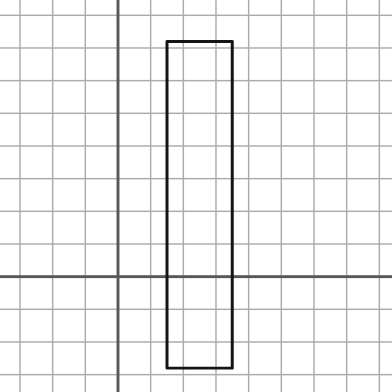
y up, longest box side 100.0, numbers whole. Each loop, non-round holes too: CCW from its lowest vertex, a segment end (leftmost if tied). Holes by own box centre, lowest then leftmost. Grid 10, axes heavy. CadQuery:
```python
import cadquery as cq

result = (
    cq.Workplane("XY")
    .moveTo(15.0, -28.0)
    .lineTo(35.0, -28.0)
    .lineTo(35.0, 72.0)
    .lineTo(15.0, 72.0)
    .close()
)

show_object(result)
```